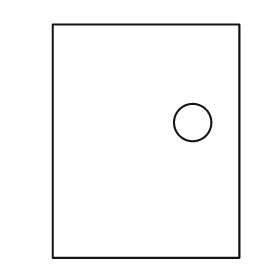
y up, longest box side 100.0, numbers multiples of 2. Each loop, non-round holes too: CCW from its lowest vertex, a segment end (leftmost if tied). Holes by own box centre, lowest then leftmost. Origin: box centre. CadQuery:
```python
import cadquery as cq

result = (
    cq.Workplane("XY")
    .moveTo(-40.0, -50.0)
    .lineTo(40.0, -50.0)
    .lineTo(40.0, 50.0)
    .lineTo(-40.0, 50.0)
    .close()
    .moveTo(20.0, 8.0)
    .circle(8.0)
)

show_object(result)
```